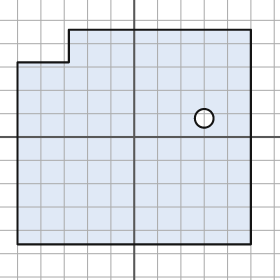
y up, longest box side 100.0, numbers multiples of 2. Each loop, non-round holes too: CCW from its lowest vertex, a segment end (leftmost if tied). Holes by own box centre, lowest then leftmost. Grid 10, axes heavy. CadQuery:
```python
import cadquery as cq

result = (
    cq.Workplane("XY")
    .moveTo(-50.0, -46.0)
    .lineTo(50.0, -46.0)
    .lineTo(50.0, 46.0)
    .lineTo(-28.0, 46.0)
    .lineTo(-28.0, 32.0)
    .lineTo(-50.0, 32.0)
    .close()
    .moveTo(30.0, 8.0)
    .circle(4.0)
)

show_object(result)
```